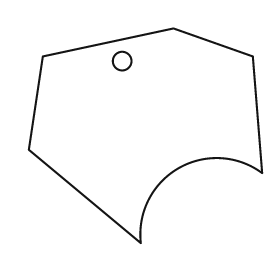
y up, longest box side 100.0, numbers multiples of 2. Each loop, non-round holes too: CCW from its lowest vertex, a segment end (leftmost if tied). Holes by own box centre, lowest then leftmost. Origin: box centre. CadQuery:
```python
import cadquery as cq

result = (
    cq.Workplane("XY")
    .moveTo(-2.0, -46.0)
    .threePointArc((14.0, -14.0), (50.0, -16.0))
    .lineTo(46.0, 34.0)
    .lineTo(12.0, 46.0)
    .lineTo(-44.0, 34.0)
    .lineTo(-50.0, -6.0)
    .close()
    .moveTo(-10.0, 32.0)
    .circle(4.0)
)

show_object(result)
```